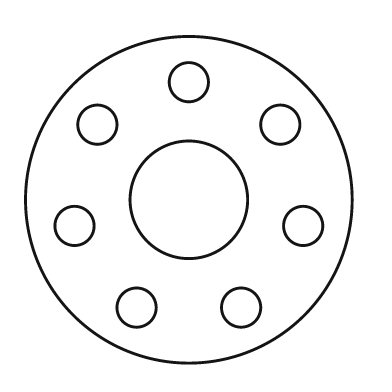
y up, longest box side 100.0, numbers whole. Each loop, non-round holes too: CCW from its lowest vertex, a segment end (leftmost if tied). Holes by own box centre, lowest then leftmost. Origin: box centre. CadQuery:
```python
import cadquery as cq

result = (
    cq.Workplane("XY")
    .moveTo(0.0, 0.0)
    .circle(50.0)
    .moveTo(-16.0, -33.0)
    .circle(6.0)
    .moveTo(16.0, -33.0)
    .circle(6.0)
    .moveTo(-35.0, -8.0)
    .circle(6.0)
    .moveTo(35.0, -8.0)
    .circle(6.0)
    .moveTo(0.0, 0.0)
    .circle(18.0)
    .moveTo(-28.0, 23.0)
    .circle(6.0)
    .moveTo(28.0, 23.0)
    .circle(6.0)
    .moveTo(0.0, 36.0)
    .circle(6.0)
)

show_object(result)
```